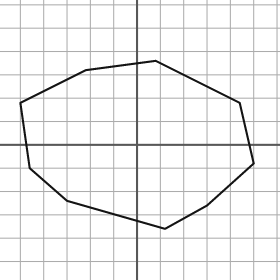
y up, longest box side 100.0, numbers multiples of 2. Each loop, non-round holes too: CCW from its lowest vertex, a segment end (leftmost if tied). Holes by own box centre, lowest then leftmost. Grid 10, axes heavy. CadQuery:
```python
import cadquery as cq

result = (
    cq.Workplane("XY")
    .moveTo(12.0, -36.0)
    .lineTo(30.0, -26.0)
    .lineTo(50.0, -8.0)
    .lineTo(44.0, 18.0)
    .lineTo(8.0, 36.0)
    .lineTo(-22.0, 32.0)
    .lineTo(-50.0, 18.0)
    .lineTo(-46.0, -10.0)
    .lineTo(-30.0, -24.0)
    .close()
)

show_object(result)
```